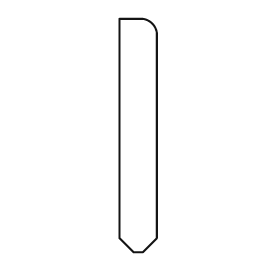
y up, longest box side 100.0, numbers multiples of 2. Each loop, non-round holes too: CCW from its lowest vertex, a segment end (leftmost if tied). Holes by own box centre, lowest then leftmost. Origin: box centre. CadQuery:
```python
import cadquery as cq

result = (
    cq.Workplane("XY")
    .moveTo(-2.0, -50.0)
    .lineTo(2.0, -50.0)
    .lineTo(8.0, -44.0)
    .lineTo(8.0, 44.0)
    .threePointArc((6.0, 48.0), (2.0, 50.0))
    .lineTo(-8.0, 50.0)
    .lineTo(-8.0, -44.0)
    .close()
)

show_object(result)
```